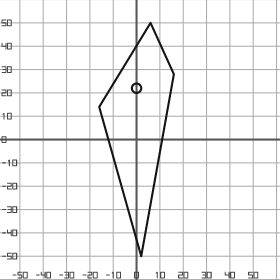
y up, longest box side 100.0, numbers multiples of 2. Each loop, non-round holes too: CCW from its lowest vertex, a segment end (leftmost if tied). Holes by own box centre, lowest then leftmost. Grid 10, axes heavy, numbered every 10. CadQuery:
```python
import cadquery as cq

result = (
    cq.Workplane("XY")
    .moveTo(2.0, -50.0)
    .lineTo(16.0, 28.0)
    .lineTo(6.0, 50.0)
    .lineTo(-16.0, 14.0)
    .close()
    .moveTo(0.0, 22.0)
    .circle(2.0)
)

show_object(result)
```